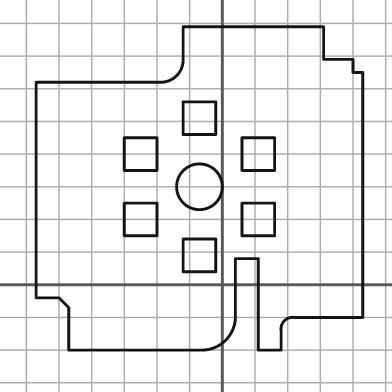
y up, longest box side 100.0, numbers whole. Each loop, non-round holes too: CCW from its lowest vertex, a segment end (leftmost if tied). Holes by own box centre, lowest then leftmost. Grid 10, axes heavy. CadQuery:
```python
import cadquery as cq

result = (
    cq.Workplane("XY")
    .moveTo(-47.0, -20.0)
    .lineTo(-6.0, -20.0)
    .threePointArc((1.0, -17.0), (4.0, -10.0))
    .lineTo(4.0, 8.0)
    .lineTo(11.0, 8.0)
    .lineTo(11.0, -20.0)
    .lineTo(18.0, -20.0)
    .lineTo(18.0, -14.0)
    .threePointArc((19.0, -11.0), (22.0, -10.0))
    .lineTo(43.0, -10.0)
    .lineTo(43.0, 65.0)
    .lineTo(40.0, 65.0)
    .lineTo(40.0, 69.0)
    .lineTo(31.0, 69.0)
    .lineTo(31.0, 79.0)
    .lineTo(-12.0, 79.0)
    .lineTo(-12.0, 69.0)
    .threePointArc((-14.0, 64.0), (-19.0, 62.0))
    .lineTo(-57.0, 62.0)
    .lineTo(-57.0, -4.0)
    .lineTo(-50.0, -4.0)
    .lineTo(-47.0, -7.0)
    .close()
    .moveTo(-12.0, 4.0)
    .lineTo(-2.0, 4.0)
    .lineTo(-2.0, 14.0)
    .lineTo(-12.0, 14.0)
    .close()
    .moveTo(-30.0, 15.0)
    .lineTo(-20.0, 15.0)
    .lineTo(-20.0, 25.0)
    .lineTo(-30.0, 25.0)
    .close()
    .moveTo(6.0, 15.0)
    .lineTo(16.0, 15.0)
    .lineTo(16.0, 25.0)
    .lineTo(6.0, 25.0)
    .close()
    .moveTo(-7.0, 30.0)
    .circle(7.0)
    .moveTo(-30.0, 35.0)
    .lineTo(-20.0, 35.0)
    .lineTo(-20.0, 45.0)
    .lineTo(-30.0, 45.0)
    .close()
    .moveTo(6.0, 35.0)
    .lineTo(16.0, 35.0)
    .lineTo(16.0, 45.0)
    .lineTo(6.0, 45.0)
    .close()
    .moveTo(-12.0, 46.0)
    .lineTo(-2.0, 46.0)
    .lineTo(-2.0, 56.0)
    .lineTo(-12.0, 56.0)
    .close()
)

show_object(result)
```